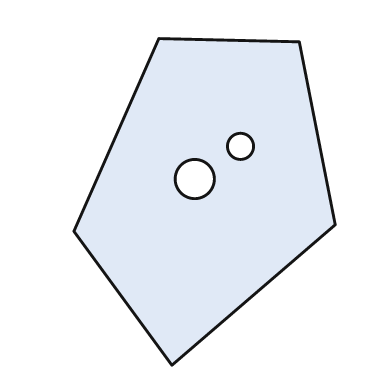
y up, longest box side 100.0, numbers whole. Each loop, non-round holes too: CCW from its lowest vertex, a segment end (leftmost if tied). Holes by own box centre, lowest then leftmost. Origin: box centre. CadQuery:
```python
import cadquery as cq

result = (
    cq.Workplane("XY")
    .moveTo(-10.0, -50.0)
    .lineTo(40.0, -7.0)
    .lineTo(29.0, 49.0)
    .lineTo(-14.0, 50.0)
    .lineTo(-40.0, -9.0)
    .close()
    .moveTo(-3.0, 7.0)
    .circle(6.0)
    .moveTo(11.0, 17.0)
    .circle(4.0)
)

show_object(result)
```